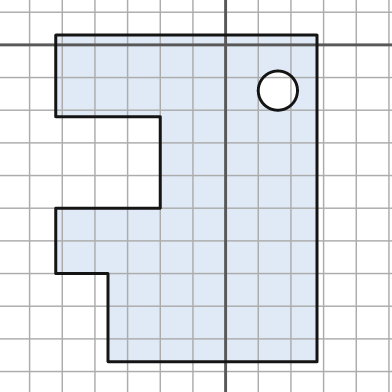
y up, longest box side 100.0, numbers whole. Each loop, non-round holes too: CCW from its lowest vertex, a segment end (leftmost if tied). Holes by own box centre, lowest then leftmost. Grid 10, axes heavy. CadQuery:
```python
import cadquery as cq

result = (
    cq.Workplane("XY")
    .moveTo(-36.0, -97.0)
    .lineTo(28.0, -97.0)
    .lineTo(28.0, 3.0)
    .lineTo(-52.0, 3.0)
    .lineTo(-52.0, -22.0)
    .lineTo(-20.0, -22.0)
    .lineTo(-20.0, -50.0)
    .lineTo(-52.0, -50.0)
    .lineTo(-52.0, -70.0)
    .lineTo(-36.0, -70.0)
    .close()
    .moveTo(16.0, -14.0)
    .circle(6.0)
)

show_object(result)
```